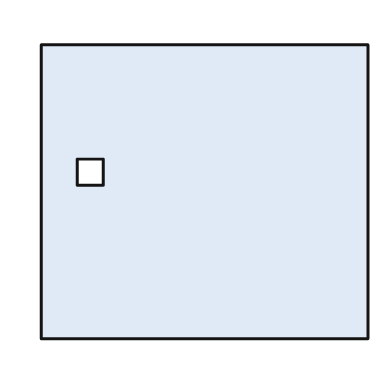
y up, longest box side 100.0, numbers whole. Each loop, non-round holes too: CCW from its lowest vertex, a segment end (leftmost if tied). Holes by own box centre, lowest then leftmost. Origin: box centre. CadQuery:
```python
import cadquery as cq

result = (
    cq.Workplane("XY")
    .moveTo(-50.0, -45.0)
    .lineTo(50.0, -45.0)
    .lineTo(50.0, 45.0)
    .lineTo(-50.0, 45.0)
    .close()
    .moveTo(-39.0, 2.0)
    .lineTo(-31.0, 2.0)
    .lineTo(-31.0, 10.0)
    .lineTo(-39.0, 10.0)
    .close()
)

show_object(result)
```